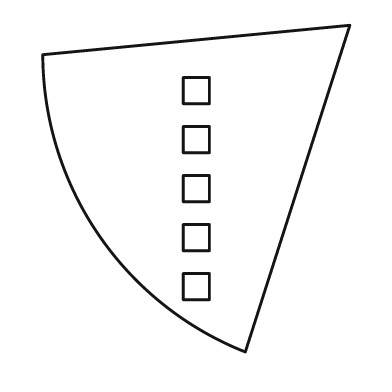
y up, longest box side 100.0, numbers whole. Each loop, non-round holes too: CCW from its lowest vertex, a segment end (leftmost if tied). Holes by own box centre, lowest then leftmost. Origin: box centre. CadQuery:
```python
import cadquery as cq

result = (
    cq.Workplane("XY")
    .moveTo(15.0, -50.0)
    .lineTo(47.0, 50.0)
    .lineTo(-47.0, 41.0)
    .threePointArc((-30.0, -14.0), (15.0, -50.0))
    .close()
    .moveTo(-4.0, -34.0)
    .lineTo(4.0, -34.0)
    .lineTo(4.0, -26.0)
    .lineTo(-4.0, -26.0)
    .close()
    .moveTo(-4.0, -19.0)
    .lineTo(4.0, -19.0)
    .lineTo(4.0, -11.0)
    .lineTo(-4.0, -11.0)
    .close()
    .moveTo(-4.0, -4.0)
    .lineTo(4.0, -4.0)
    .lineTo(4.0, 4.0)
    .lineTo(-4.0, 4.0)
    .close()
    .moveTo(-4.0, 11.0)
    .lineTo(4.0, 11.0)
    .lineTo(4.0, 19.0)
    .lineTo(-4.0, 19.0)
    .close()
    .moveTo(-4.0, 26.0)
    .lineTo(4.0, 26.0)
    .lineTo(4.0, 34.0)
    .lineTo(-4.0, 34.0)
    .close()
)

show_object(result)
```